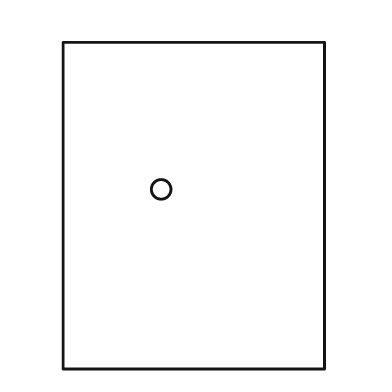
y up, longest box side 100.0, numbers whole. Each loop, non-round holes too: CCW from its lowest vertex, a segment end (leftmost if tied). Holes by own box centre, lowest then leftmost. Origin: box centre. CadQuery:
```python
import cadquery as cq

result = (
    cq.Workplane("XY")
    .moveTo(-40.0, -50.0)
    .lineTo(40.0, -50.0)
    .lineTo(40.0, 50.0)
    .lineTo(-40.0, 50.0)
    .close()
    .moveTo(-10.0, 5.0)
    .circle(3.0)
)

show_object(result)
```